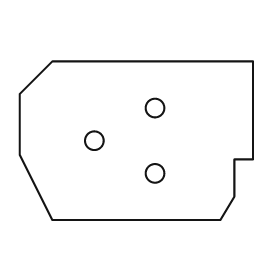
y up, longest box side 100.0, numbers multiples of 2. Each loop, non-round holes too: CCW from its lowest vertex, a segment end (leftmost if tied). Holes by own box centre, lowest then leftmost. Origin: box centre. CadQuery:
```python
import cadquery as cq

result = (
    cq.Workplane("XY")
    .moveTo(-36.0, -34.0)
    .lineTo(36.0, -34.0)
    .lineTo(42.0, -24.0)
    .lineTo(42.0, -8.0)
    .lineTo(50.0, -8.0)
    .lineTo(50.0, 34.0)
    .lineTo(-36.0, 34.0)
    .lineTo(-50.0, 20.0)
    .lineTo(-50.0, -6.0)
    .close()
    .moveTo(8.0, -14.0)
    .circle(4.0)
    .moveTo(-18.0, 0.0)
    .circle(4.0)
    .moveTo(8.0, 14.0)
    .circle(4.0)
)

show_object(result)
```